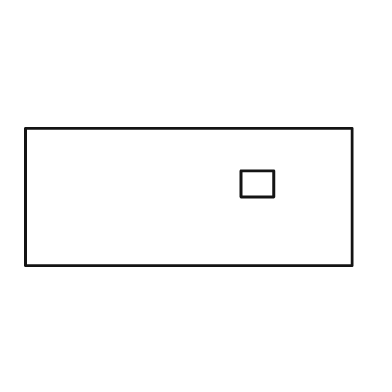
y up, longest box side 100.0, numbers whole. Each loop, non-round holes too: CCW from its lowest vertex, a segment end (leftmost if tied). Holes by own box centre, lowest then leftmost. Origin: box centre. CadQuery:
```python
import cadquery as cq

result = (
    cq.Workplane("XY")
    .moveTo(-50.0, -21.0)
    .lineTo(50.0, -21.0)
    .lineTo(50.0, 21.0)
    .lineTo(-50.0, 21.0)
    .close()
    .moveTo(16.0, 0.0)
    .lineTo(26.0, 0.0)
    .lineTo(26.0, 8.0)
    .lineTo(16.0, 8.0)
    .close()
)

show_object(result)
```